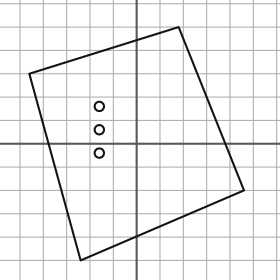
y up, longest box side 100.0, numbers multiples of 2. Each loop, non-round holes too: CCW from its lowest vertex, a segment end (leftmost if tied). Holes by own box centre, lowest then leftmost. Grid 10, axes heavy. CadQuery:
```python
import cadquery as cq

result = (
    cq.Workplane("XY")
    .moveTo(-24.0, -50.0)
    .lineTo(46.0, -20.0)
    .lineTo(18.0, 50.0)
    .lineTo(-46.0, 30.0)
    .close()
    .moveTo(-16.0, -4.0)
    .circle(2.0)
    .moveTo(-16.0, 6.0)
    .circle(2.0)
    .moveTo(-16.0, 16.0)
    .circle(2.0)
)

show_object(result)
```